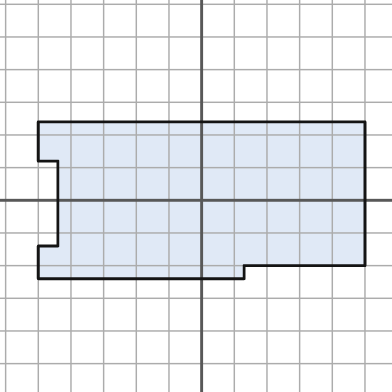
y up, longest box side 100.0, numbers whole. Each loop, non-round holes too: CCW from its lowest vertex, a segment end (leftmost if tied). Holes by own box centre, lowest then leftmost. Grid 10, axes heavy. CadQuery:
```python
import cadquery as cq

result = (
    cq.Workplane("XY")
    .moveTo(-50.0, -24.0)
    .lineTo(13.0, -24.0)
    .lineTo(13.0, -20.0)
    .lineTo(50.0, -20.0)
    .lineTo(50.0, 24.0)
    .lineTo(-50.0, 24.0)
    .lineTo(-50.0, 12.0)
    .lineTo(-44.0, 12.0)
    .lineTo(-44.0, -14.0)
    .lineTo(-50.0, -14.0)
    .close()
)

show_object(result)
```